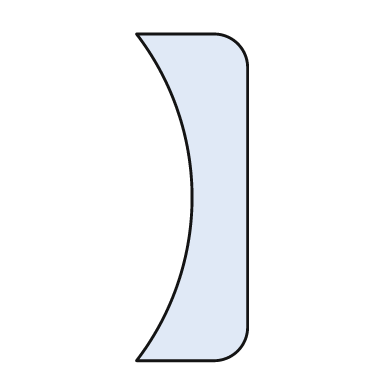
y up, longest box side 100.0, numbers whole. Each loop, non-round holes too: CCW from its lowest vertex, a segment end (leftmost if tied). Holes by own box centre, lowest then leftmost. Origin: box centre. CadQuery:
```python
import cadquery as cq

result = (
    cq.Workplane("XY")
    .moveTo(-17.0, -50.0)
    .lineTo(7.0, -50.0)
    .threePointArc((14.0, -47.0), (17.0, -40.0))
    .lineTo(17.0, 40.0)
    .threePointArc((14.0, 47.0), (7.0, 50.0))
    .lineTo(-17.0, 50.0)
    .threePointArc((0.0, 0.0), (-17.0, -50.0))
    .close()
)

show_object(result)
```